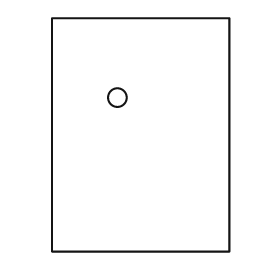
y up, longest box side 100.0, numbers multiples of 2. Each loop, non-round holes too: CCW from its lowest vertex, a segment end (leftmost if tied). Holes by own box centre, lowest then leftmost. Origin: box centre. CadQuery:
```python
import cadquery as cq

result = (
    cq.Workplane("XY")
    .moveTo(-38.0, -50.0)
    .lineTo(38.0, -50.0)
    .lineTo(38.0, 50.0)
    .lineTo(-38.0, 50.0)
    .close()
    .moveTo(-10.0, 16.0)
    .circle(4.0)
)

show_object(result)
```